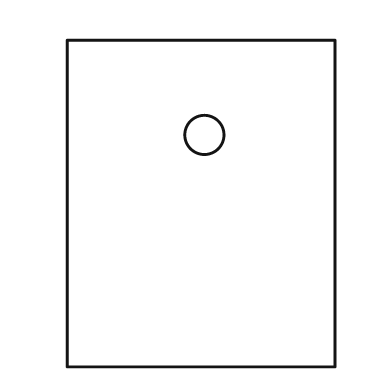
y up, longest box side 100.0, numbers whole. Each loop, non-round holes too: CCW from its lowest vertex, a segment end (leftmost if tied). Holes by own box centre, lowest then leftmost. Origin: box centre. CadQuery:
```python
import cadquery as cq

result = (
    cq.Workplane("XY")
    .moveTo(-41.0, -50.0)
    .lineTo(41.0, -50.0)
    .lineTo(41.0, 50.0)
    .lineTo(-41.0, 50.0)
    .close()
    .moveTo(1.0, 21.0)
    .circle(6.0)
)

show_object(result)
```